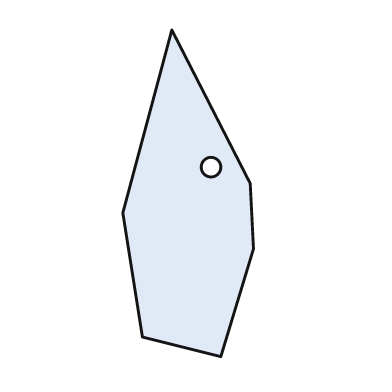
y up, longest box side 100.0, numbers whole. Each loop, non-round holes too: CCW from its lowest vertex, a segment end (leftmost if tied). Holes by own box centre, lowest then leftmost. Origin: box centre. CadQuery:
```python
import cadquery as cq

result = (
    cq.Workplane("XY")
    .moveTo(10.0, -50.0)
    .lineTo(20.0, -17.0)
    .lineTo(19.0, 3.0)
    .lineTo(-5.0, 50.0)
    .lineTo(-20.0, -6.0)
    .lineTo(-14.0, -44.0)
    .close()
    .moveTo(7.0, 8.0)
    .circle(3.0)
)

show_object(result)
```